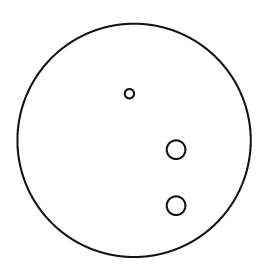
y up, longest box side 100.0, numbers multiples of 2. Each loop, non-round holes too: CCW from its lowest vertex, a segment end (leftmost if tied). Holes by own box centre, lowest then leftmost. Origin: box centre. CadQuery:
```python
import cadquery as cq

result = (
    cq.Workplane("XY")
    .moveTo(0.0, 0.0)
    .circle(50.0)
    .moveTo(18.0, -28.0)
    .circle(4.0)
    .moveTo(18.0, -4.0)
    .circle(4.0)
    .moveTo(-2.0, 20.0)
    .circle(2.0)
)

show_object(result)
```